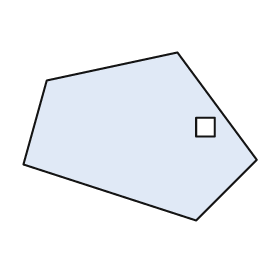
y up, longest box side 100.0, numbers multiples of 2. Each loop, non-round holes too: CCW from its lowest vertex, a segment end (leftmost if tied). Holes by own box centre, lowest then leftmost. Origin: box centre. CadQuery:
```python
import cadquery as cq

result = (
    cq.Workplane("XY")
    .moveTo(24.0, -36.0)
    .lineTo(50.0, -10.0)
    .lineTo(16.0, 36.0)
    .lineTo(-40.0, 24.0)
    .lineTo(-50.0, -12.0)
    .close()
    .moveTo(24.0, 0.0)
    .lineTo(32.0, 0.0)
    .lineTo(32.0, 8.0)
    .lineTo(24.0, 8.0)
    .close()
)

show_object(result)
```